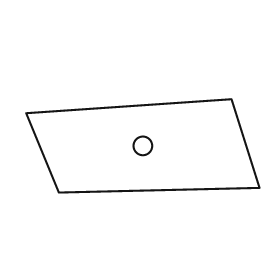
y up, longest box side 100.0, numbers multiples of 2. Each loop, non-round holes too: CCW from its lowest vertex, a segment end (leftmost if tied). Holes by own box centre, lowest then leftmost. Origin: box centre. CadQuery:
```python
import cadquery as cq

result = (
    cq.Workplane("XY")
    .moveTo(-36.0, -20.0)
    .lineTo(50.0, -18.0)
    .lineTo(38.0, 20.0)
    .lineTo(-50.0, 14.0)
    .close()
    .moveTo(0.0, 0.0)
    .circle(4.0)
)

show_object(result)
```